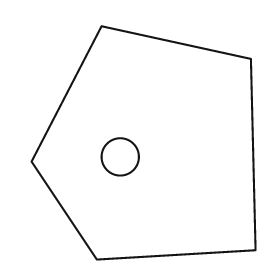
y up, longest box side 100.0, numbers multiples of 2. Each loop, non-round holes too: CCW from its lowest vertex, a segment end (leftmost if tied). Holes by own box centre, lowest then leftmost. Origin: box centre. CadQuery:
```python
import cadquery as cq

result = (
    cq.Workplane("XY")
    .moveTo(-20.0, -50.0)
    .lineTo(48.0, -46.0)
    .lineTo(46.0, 36.0)
    .lineTo(-18.0, 50.0)
    .lineTo(-48.0, -8.0)
    .close()
    .moveTo(-10.0, -6.0)
    .circle(8.0)
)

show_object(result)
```